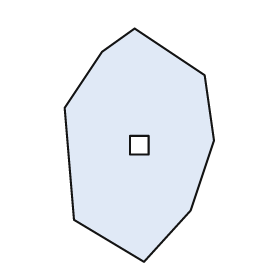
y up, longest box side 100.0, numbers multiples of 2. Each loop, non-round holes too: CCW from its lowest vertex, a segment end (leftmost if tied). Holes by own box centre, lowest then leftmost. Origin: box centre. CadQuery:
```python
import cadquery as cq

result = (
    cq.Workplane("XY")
    .moveTo(2.0, -50.0)
    .lineTo(22.0, -28.0)
    .lineTo(32.0, 2.0)
    .lineTo(28.0, 30.0)
    .lineTo(-2.0, 50.0)
    .lineTo(-16.0, 40.0)
    .lineTo(-32.0, 16.0)
    .lineTo(-28.0, -32.0)
    .close()
    .moveTo(-4.0, -4.0)
    .lineTo(4.0, -4.0)
    .lineTo(4.0, 4.0)
    .lineTo(-4.0, 4.0)
    .close()
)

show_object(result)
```